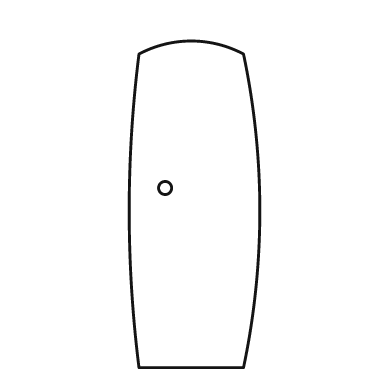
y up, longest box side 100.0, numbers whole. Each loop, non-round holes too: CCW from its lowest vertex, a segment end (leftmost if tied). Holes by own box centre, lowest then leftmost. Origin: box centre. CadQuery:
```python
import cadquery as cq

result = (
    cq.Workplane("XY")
    .moveTo(-17.0, -50.0)
    .lineTo(15.0, -50.0)
    .threePointArc((20.0, -2.0), (15.0, 46.0))
    .threePointArc((-1.0, 50.0), (-17.0, 46.0))
    .threePointArc((-20.0, -2.0), (-17.0, -50.0))
    .close()
    .moveTo(-9.0, 5.0)
    .circle(2.0)
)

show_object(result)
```